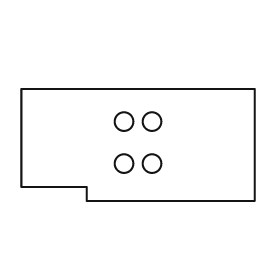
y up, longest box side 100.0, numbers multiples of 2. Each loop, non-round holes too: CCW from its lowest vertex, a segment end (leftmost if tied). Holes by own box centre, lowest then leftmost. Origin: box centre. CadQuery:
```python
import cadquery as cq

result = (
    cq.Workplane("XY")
    .moveTo(-22.0, -24.0)
    .lineTo(50.0, -24.0)
    .lineTo(50.0, 24.0)
    .lineTo(-50.0, 24.0)
    .lineTo(-50.0, -18.0)
    .lineTo(-22.0, -18.0)
    .close()
    .moveTo(-6.0, -8.0)
    .circle(4.0)
    .moveTo(6.0, -8.0)
    .circle(4.0)
    .moveTo(-6.0, 10.0)
    .circle(4.0)
    .moveTo(6.0, 10.0)
    .circle(4.0)
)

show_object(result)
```